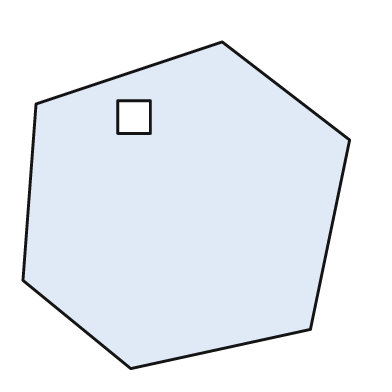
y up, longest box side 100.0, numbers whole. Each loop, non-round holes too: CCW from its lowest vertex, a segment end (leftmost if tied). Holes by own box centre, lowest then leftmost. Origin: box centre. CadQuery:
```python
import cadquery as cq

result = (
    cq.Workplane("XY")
    .moveTo(-17.0, -50.0)
    .lineTo(38.0, -38.0)
    .lineTo(50.0, 20.0)
    .lineTo(11.0, 50.0)
    .lineTo(-46.0, 31.0)
    .lineTo(-50.0, -23.0)
    .close()
    .moveTo(-21.0, 22.0)
    .lineTo(-11.0, 22.0)
    .lineTo(-11.0, 32.0)
    .lineTo(-21.0, 32.0)
    .close()
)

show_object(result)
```